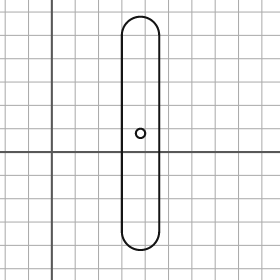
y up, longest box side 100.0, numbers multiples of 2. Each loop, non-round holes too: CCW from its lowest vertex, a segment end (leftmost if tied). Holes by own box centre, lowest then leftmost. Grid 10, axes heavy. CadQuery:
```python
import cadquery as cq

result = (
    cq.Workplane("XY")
    .moveTo(30.0, -34.0)
    .threePointArc((38.0, -42.0), (46.0, -34.0))
    .lineTo(46.0, 50.0)
    .threePointArc((38.0, 58.0), (30.0, 50.0))
    .close()
    .moveTo(38.0, 8.0)
    .circle(2.0)
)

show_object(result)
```